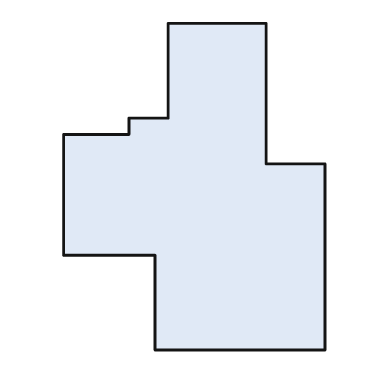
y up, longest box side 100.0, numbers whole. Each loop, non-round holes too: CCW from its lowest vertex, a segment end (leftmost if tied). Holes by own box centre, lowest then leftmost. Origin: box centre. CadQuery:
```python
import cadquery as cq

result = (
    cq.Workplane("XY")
    .moveTo(-12.0, -50.0)
    .lineTo(40.0, -50.0)
    .lineTo(40.0, 7.0)
    .lineTo(22.0, 7.0)
    .lineTo(22.0, 50.0)
    .lineTo(-8.0, 50.0)
    .lineTo(-8.0, 21.0)
    .lineTo(-20.0, 21.0)
    .lineTo(-20.0, 16.0)
    .lineTo(-40.0, 16.0)
    .lineTo(-40.0, -21.0)
    .lineTo(-12.0, -21.0)
    .close()
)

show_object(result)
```